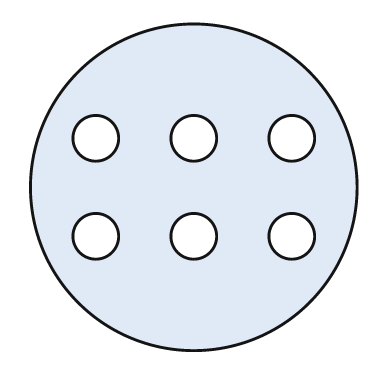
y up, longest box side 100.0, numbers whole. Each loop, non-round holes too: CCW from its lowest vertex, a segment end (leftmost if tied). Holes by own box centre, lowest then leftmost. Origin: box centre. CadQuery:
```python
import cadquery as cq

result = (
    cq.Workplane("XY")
    .moveTo(0.0, 0.0)
    .circle(50.0)
    .moveTo(-30.0, -15.0)
    .circle(7.0)
    .moveTo(0.0, -15.0)
    .circle(7.0)
    .moveTo(30.0, -15.0)
    .circle(7.0)
    .moveTo(-30.0, 15.0)
    .circle(7.0)
    .moveTo(0.0, 15.0)
    .circle(7.0)
    .moveTo(30.0, 15.0)
    .circle(7.0)
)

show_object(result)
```